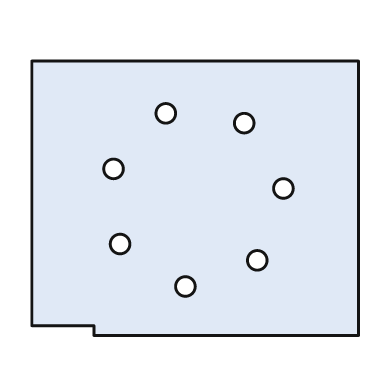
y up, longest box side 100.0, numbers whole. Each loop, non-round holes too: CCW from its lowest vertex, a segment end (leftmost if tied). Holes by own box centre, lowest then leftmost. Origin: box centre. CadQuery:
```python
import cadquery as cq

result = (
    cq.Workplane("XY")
    .moveTo(-31.0, -42.0)
    .lineTo(50.0, -42.0)
    .lineTo(50.0, 42.0)
    .lineTo(-50.0, 42.0)
    .lineTo(-50.0, -39.0)
    .lineTo(-31.0, -39.0)
    .close()
    .moveTo(-3.0, -27.0)
    .circle(3.0)
    .moveTo(19.0, -19.0)
    .circle(3.0)
    .moveTo(-23.0, -14.0)
    .circle(3.0)
    .moveTo(27.0, 3.0)
    .circle(3.0)
    .moveTo(-25.0, 9.0)
    .circle(3.0)
    .moveTo(15.0, 23.0)
    .circle(3.0)
    .moveTo(-9.0, 26.0)
    .circle(3.0)
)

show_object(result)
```